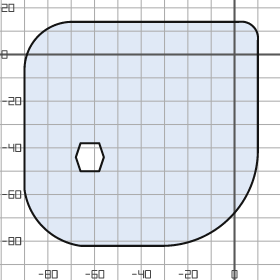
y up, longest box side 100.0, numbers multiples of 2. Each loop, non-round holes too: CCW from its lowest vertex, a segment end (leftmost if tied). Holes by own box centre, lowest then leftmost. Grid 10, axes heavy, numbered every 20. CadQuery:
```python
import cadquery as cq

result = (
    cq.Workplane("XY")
    .moveTo(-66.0, -82.0)
    .lineTo(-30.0, -82.0)
    .threePointArc((-2.0, -70.0), (10.0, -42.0))
    .lineTo(10.0, 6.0)
    .threePointArc((8.0, 12.0), (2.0, 14.0))
    .lineTo(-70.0, 14.0)
    .threePointArc((-84.0, 8.0), (-90.0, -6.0))
    .lineTo(-90.0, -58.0)
    .threePointArc((-82.0, -74.0), (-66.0, -82.0))
    .close()
    .moveTo(-66.0, -50.0)
    .lineTo(-58.0, -50.0)
    .lineTo(-56.0, -44.0)
    .lineTo(-58.0, -38.0)
    .lineTo(-66.0, -38.0)
    .lineTo(-68.0, -44.0)
    .close()
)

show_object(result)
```